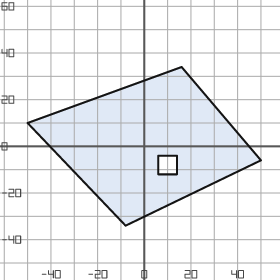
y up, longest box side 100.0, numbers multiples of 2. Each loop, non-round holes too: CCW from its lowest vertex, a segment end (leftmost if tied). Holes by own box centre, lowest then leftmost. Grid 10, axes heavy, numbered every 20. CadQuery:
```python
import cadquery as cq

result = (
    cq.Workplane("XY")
    .moveTo(-8.0, -34.0)
    .lineTo(50.0, -6.0)
    .lineTo(16.0, 34.0)
    .lineTo(-50.0, 10.0)
    .close()
    .moveTo(6.0, -12.0)
    .lineTo(14.0, -12.0)
    .lineTo(14.0, -4.0)
    .lineTo(6.0, -4.0)
    .close()
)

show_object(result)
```